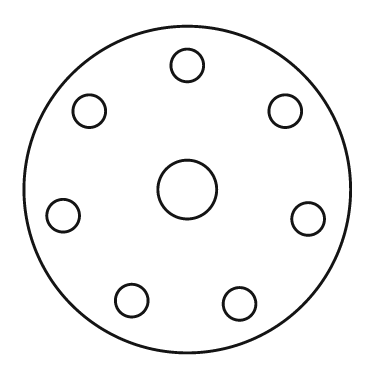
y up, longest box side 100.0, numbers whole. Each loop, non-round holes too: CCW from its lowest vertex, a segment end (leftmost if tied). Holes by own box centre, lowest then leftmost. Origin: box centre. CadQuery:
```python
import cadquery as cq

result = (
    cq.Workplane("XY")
    .moveTo(0.0, 0.0)
    .circle(50.0)
    .moveTo(16.0, -35.0)
    .circle(5.0)
    .moveTo(-17.0, -34.0)
    .circle(5.0)
    .moveTo(37.0, -9.0)
    .circle(5.0)
    .moveTo(-38.0, -8.0)
    .circle(5.0)
    .moveTo(0.0, 0.0)
    .circle(9.0)
    .moveTo(-30.0, 24.0)
    .circle(5.0)
    .moveTo(30.0, 24.0)
    .circle(5.0)
    .moveTo(0.0, 38.0)
    .circle(5.0)
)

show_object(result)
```